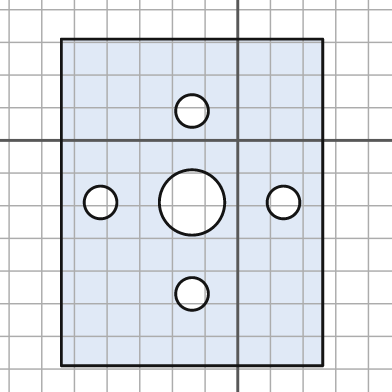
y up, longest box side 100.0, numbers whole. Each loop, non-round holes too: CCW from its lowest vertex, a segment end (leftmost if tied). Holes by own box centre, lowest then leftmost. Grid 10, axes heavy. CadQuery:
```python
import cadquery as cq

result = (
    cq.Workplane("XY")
    .moveTo(-54.0, -69.0)
    .lineTo(26.0, -69.0)
    .lineTo(26.0, 31.0)
    .lineTo(-54.0, 31.0)
    .close()
    .moveTo(-14.0, -47.0)
    .circle(5.0)
    .moveTo(-42.0, -19.0)
    .circle(5.0)
    .moveTo(-14.0, -19.0)
    .circle(10.0)
    .moveTo(14.0, -19.0)
    .circle(5.0)
    .moveTo(-14.0, 9.0)
    .circle(5.0)
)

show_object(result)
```